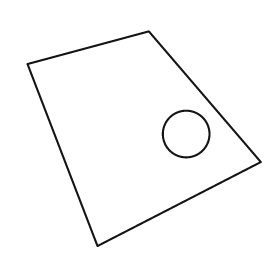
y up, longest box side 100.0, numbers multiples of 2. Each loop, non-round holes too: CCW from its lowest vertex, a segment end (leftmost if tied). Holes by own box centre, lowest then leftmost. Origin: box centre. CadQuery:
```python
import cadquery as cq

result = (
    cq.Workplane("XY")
    .moveTo(-20.0, -46.0)
    .lineTo(50.0, -10.0)
    .lineTo(2.0, 46.0)
    .lineTo(-50.0, 32.0)
    .close()
    .moveTo(18.0, 2.0)
    .circle(10.0)
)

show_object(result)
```